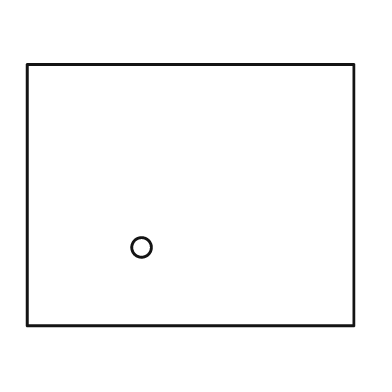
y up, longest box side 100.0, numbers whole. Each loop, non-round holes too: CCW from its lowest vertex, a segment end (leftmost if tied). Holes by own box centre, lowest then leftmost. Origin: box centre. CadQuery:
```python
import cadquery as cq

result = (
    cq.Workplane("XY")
    .moveTo(-50.0, -40.0)
    .lineTo(50.0, -40.0)
    .lineTo(50.0, 40.0)
    .lineTo(-50.0, 40.0)
    .close()
    .moveTo(-15.0, -16.0)
    .circle(3.0)
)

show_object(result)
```